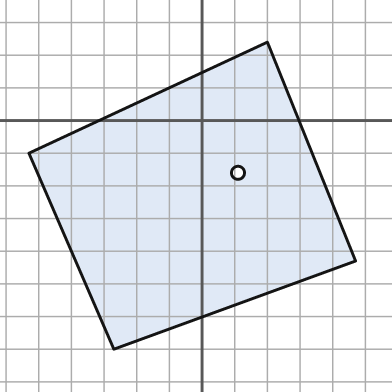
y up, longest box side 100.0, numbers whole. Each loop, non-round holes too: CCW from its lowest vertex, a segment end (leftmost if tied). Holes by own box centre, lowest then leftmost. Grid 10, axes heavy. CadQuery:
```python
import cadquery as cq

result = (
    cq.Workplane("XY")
    .moveTo(-27.0, -70.0)
    .lineTo(47.0, -43.0)
    .lineTo(20.0, 24.0)
    .lineTo(-53.0, -10.0)
    .close()
    .moveTo(11.0, -16.0)
    .circle(2.0)
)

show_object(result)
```